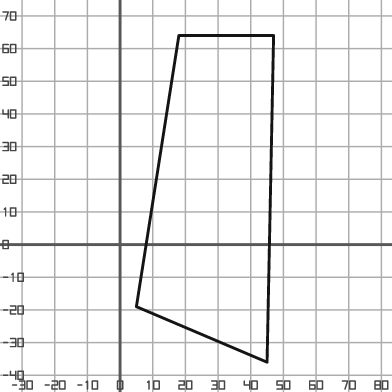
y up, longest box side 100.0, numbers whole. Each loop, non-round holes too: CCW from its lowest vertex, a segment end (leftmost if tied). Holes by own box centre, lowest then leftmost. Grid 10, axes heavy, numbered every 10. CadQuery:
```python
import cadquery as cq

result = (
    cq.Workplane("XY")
    .moveTo(45.0, -36.0)
    .lineTo(47.0, 64.0)
    .lineTo(18.0, 64.0)
    .lineTo(5.0, -19.0)
    .close()
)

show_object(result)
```